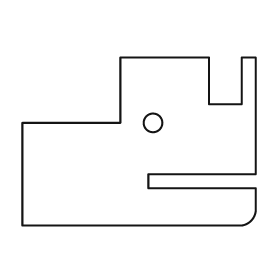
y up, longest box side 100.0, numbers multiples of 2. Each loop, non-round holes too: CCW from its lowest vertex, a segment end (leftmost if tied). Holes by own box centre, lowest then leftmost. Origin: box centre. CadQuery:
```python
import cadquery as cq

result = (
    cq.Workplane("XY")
    .moveTo(-50.0, -36.0)
    .lineTo(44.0, -36.0)
    .threePointArc((48.0, -34.0), (50.0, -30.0))
    .lineTo(50.0, -20.0)
    .lineTo(4.0, -20.0)
    .lineTo(4.0, -14.0)
    .lineTo(50.0, -14.0)
    .lineTo(50.0, 36.0)
    .lineTo(44.0, 36.0)
    .lineTo(44.0, 16.0)
    .lineTo(30.0, 16.0)
    .lineTo(30.0, 36.0)
    .lineTo(-8.0, 36.0)
    .lineTo(-8.0, 8.0)
    .lineTo(-50.0, 8.0)
    .close()
    .moveTo(6.0, 8.0)
    .circle(4.0)
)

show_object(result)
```